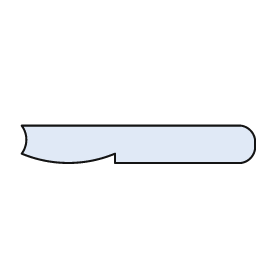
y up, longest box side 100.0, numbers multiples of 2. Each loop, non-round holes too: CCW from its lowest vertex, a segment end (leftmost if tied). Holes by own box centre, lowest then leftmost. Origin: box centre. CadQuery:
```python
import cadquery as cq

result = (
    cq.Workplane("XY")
    .moveTo(-10.0, -8.0)
    .lineTo(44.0, -8.0)
    .threePointArc((48.0, -6.0), (50.0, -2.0))
    .lineTo(50.0, 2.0)
    .threePointArc((48.0, 6.0), (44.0, 8.0))
    .lineTo(-50.0, 8.0)
    .threePointArc((-48.0, 2.0), (-50.0, -4.0))
    .threePointArc((-30.0, -8.0), (-10.0, -4.0))
    .close()
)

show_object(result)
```